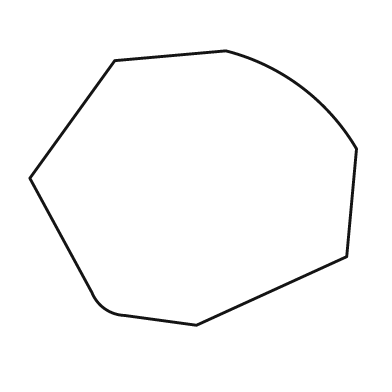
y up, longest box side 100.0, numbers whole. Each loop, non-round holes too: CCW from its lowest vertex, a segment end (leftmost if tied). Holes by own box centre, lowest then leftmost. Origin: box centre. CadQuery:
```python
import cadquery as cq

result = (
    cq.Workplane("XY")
    .moveTo(1.0, -42.0)
    .lineTo(47.0, -21.0)
    .lineTo(50.0, 12.0)
    .threePointArc((33.0, 31.0), (10.0, 42.0))
    .lineTo(-24.0, 39.0)
    .lineTo(-50.0, 3.0)
    .lineTo(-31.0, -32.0)
    .threePointArc((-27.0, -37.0), (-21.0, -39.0))
    .close()
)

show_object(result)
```